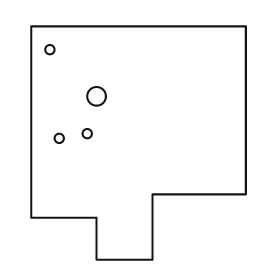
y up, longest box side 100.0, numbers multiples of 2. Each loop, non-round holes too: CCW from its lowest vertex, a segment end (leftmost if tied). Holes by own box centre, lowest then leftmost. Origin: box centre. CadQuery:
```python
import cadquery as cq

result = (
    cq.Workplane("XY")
    .moveTo(-18.0, -50.0)
    .lineTo(6.0, -50.0)
    .lineTo(6.0, -22.0)
    .lineTo(46.0, -22.0)
    .lineTo(46.0, 50.0)
    .lineTo(-46.0, 50.0)
    .lineTo(-46.0, -32.0)
    .lineTo(-18.0, -32.0)
    .close()
    .moveTo(-34.0, 2.0)
    .circle(2.0)
    .moveTo(-22.0, 4.0)
    .circle(2.0)
    .moveTo(-18.0, 20.0)
    .circle(4.0)
    .moveTo(-38.0, 40.0)
    .circle(2.0)
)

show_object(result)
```